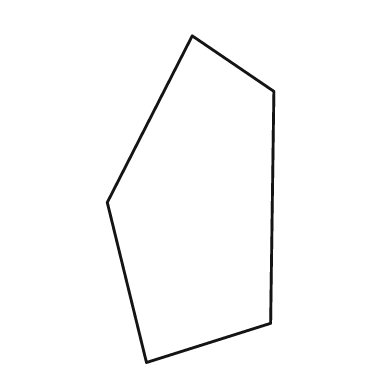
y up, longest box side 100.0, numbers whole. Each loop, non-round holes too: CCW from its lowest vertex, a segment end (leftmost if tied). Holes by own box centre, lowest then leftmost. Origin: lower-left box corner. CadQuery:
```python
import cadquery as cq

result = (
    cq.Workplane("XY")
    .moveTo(12.0, 0.0)
    .lineTo(50.0, 12.0)
    .lineTo(51.0, 83.0)
    .lineTo(26.0, 100.0)
    .lineTo(0.0, 49.0)
    .close()
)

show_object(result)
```